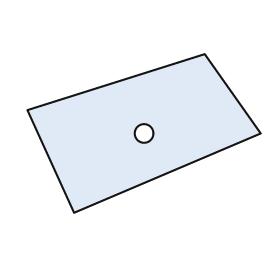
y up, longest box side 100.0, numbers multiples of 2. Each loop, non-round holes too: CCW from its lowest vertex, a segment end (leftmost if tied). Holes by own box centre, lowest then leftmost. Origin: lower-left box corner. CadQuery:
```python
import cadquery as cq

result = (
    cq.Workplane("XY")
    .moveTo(20.0, 0.0)
    .lineTo(100.0, 34.0)
    .lineTo(76.0, 68.0)
    .lineTo(0.0, 44.0)
    .close()
    .moveTo(50.0, 34.0)
    .circle(4.0)
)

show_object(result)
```